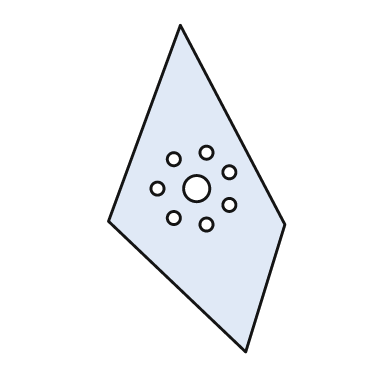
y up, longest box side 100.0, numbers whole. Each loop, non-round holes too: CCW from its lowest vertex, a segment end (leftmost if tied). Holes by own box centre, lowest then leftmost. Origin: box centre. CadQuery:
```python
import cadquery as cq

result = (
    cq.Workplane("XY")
    .moveTo(15.0, -50.0)
    .lineTo(27.0, -11.0)
    .lineTo(-5.0, 50.0)
    .lineTo(-27.0, -10.0)
    .close()
    .moveTo(3.0, -11.0)
    .circle(2.0)
    .moveTo(-7.0, -9.0)
    .circle(2.0)
    .moveTo(10.0, -5.0)
    .circle(2.0)
    .moveTo(-12.0, 0.0)
    .circle(2.0)
    .moveTo(0.0, 0.0)
    .circle(4.0)
    .moveTo(10.0, 5.0)
    .circle(2.0)
    .moveTo(-7.0, 9.0)
    .circle(2.0)
    .moveTo(3.0, 11.0)
    .circle(2.0)
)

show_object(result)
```